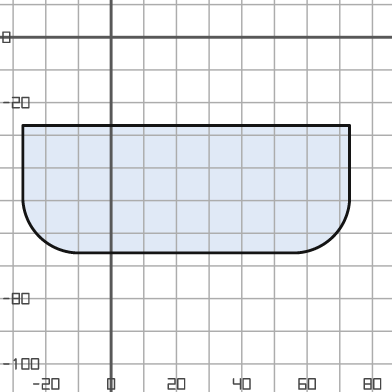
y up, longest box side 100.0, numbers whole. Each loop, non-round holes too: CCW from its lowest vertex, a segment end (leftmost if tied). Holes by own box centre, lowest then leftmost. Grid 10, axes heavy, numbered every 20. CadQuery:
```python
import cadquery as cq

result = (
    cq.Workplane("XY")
    .moveTo(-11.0, -66.0)
    .lineTo(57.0, -66.0)
    .threePointArc((68.0, -61.0), (73.0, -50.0))
    .lineTo(73.0, -27.0)
    .lineTo(-27.0, -27.0)
    .lineTo(-27.0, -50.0)
    .threePointArc((-22.0, -61.0), (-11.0, -66.0))
    .close()
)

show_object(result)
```